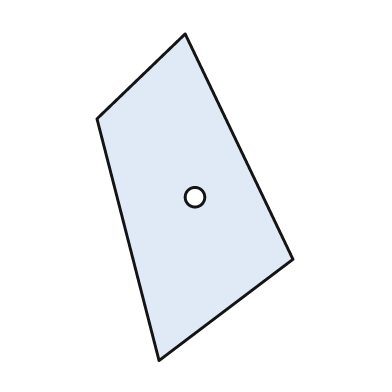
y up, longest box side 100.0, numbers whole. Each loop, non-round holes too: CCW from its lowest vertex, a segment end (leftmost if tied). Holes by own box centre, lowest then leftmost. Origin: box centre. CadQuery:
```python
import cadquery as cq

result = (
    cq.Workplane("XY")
    .moveTo(-11.0, -50.0)
    .lineTo(30.0, -19.0)
    .lineTo(-3.0, 50.0)
    .lineTo(-30.0, 24.0)
    .close()
    .moveTo(0.0, 0.0)
    .circle(3.0)
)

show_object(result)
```